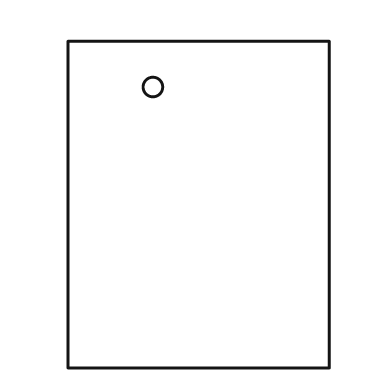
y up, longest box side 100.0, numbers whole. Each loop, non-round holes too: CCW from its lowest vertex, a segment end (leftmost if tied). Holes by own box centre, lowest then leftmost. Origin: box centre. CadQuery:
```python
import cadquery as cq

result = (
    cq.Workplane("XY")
    .moveTo(-40.0, -50.0)
    .lineTo(40.0, -50.0)
    .lineTo(40.0, 50.0)
    .lineTo(-40.0, 50.0)
    .close()
    .moveTo(-14.0, 36.0)
    .circle(3.0)
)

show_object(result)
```